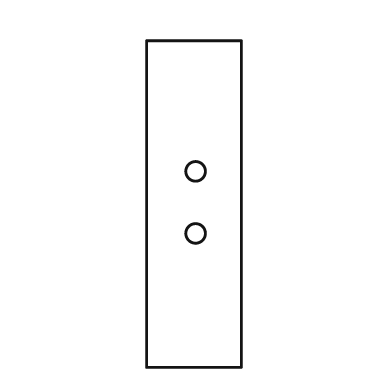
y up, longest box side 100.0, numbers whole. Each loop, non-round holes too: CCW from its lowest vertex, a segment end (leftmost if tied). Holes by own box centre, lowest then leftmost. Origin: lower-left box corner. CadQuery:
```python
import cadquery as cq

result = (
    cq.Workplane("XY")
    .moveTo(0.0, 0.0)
    .lineTo(29.0, 0.0)
    .lineTo(29.0, 100.0)
    .lineTo(0.0, 100.0)
    .close()
    .moveTo(15.0, 41.0)
    .circle(3.0)
    .moveTo(15.0, 60.0)
    .circle(3.0)
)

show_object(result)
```